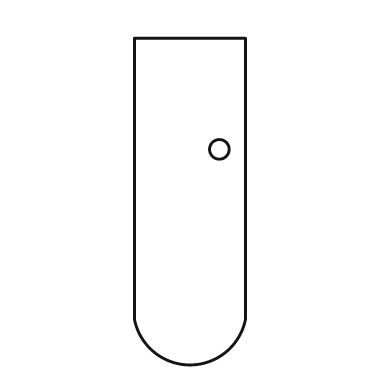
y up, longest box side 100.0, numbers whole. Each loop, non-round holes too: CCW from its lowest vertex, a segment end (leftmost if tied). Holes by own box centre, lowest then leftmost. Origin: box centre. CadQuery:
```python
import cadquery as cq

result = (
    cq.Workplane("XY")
    .moveTo(-17.0, -36.0)
    .threePointArc((0.0, -50.0), (17.0, -36.0))
    .lineTo(17.0, 50.0)
    .lineTo(-17.0, 50.0)
    .close()
    .moveTo(9.0, 16.0)
    .circle(3.0)
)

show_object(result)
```